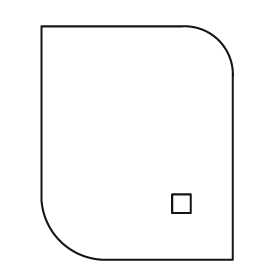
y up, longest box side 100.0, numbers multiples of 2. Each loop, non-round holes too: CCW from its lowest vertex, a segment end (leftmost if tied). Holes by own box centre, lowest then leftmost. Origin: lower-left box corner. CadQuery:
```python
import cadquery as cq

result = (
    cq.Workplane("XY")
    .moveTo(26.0, 0.0)
    .lineTo(82.0, 0.0)
    .lineTo(82.0, 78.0)
    .threePointArc((76.0, 94.0), (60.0, 100.0))
    .lineTo(0.0, 100.0)
    .lineTo(0.0, 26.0)
    .threePointArc((8.0, 8.0), (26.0, 0.0))
    .close()
    .moveTo(56.0, 20.0)
    .lineTo(64.0, 20.0)
    .lineTo(64.0, 28.0)
    .lineTo(56.0, 28.0)
    .close()
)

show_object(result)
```